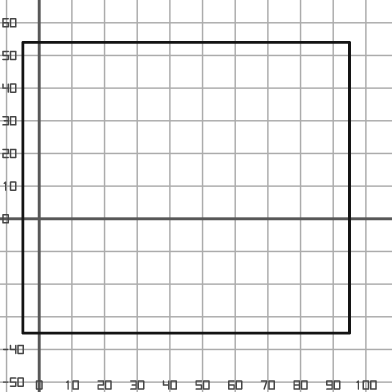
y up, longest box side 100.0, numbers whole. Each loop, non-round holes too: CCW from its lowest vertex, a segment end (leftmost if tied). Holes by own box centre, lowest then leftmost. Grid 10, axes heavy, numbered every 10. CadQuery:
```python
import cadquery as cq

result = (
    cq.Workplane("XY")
    .moveTo(-5.0, -35.0)
    .lineTo(95.0, -35.0)
    .lineTo(95.0, 54.0)
    .lineTo(-5.0, 54.0)
    .close()
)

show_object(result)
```